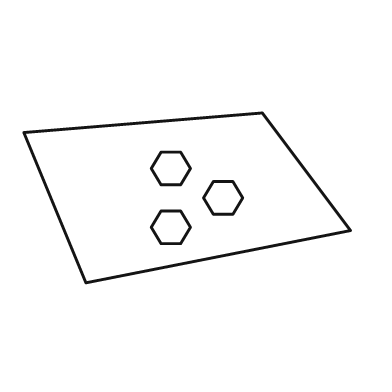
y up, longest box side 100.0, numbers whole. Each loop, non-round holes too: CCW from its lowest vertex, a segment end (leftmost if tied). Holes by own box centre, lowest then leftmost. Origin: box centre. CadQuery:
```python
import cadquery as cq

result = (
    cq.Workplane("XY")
    .moveTo(-31.0, -26.0)
    .lineTo(50.0, -10.0)
    .lineTo(23.0, 26.0)
    .lineTo(-50.0, 20.0)
    .close()
    .moveTo(-8.0, -14.0)
    .lineTo(-2.0, -14.0)
    .lineTo(1.0, -9.0)
    .lineTo(-2.0, -4.0)
    .lineTo(-8.0, -4.0)
    .lineTo(-11.0, -9.0)
    .close()
    .moveTo(8.0, -5.0)
    .lineTo(14.0, -5.0)
    .lineTo(17.0, 0.0)
    .lineTo(14.0, 5.0)
    .lineTo(8.0, 5.0)
    .lineTo(5.0, 0.0)
    .close()
    .moveTo(-8.0, 4.0)
    .lineTo(-2.0, 4.0)
    .lineTo(1.0, 9.0)
    .lineTo(-2.0, 14.0)
    .lineTo(-8.0, 14.0)
    .lineTo(-11.0, 9.0)
    .close()
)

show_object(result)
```